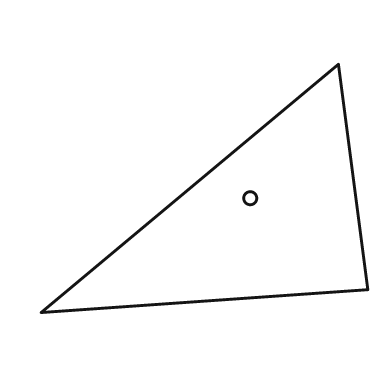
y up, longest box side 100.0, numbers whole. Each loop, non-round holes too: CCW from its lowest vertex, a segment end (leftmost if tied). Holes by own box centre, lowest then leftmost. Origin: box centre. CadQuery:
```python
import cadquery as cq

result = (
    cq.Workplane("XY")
    .moveTo(-50.0, -38.0)
    .lineTo(50.0, -31.0)
    .lineTo(41.0, 38.0)
    .close()
    .moveTo(14.0, -3.0)
    .circle(2.0)
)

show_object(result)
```